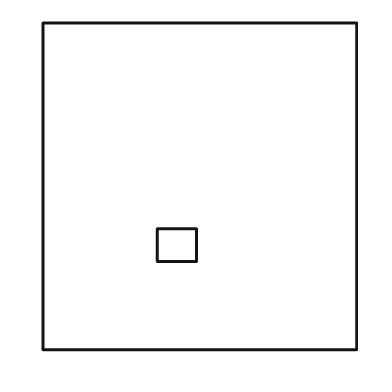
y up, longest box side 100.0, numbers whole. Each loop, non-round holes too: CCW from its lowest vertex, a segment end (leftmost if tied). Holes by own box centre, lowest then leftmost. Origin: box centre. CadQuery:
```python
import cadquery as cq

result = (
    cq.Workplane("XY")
    .moveTo(-48.0, -50.0)
    .lineTo(48.0, -50.0)
    .lineTo(48.0, 50.0)
    .lineTo(-48.0, 50.0)
    .close()
    .moveTo(-13.0, -23.0)
    .lineTo(-1.0, -23.0)
    .lineTo(-1.0, -13.0)
    .lineTo(-13.0, -13.0)
    .close()
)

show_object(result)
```